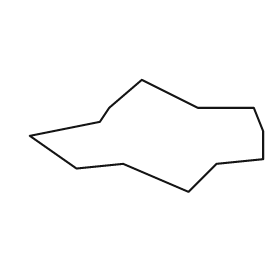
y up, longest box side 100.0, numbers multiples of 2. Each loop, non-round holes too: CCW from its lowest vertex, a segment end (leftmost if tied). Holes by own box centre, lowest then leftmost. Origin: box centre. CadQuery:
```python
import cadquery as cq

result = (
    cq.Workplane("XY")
    .moveTo(18.0, -24.0)
    .lineTo(30.0, -12.0)
    .lineTo(50.0, -10.0)
    .lineTo(50.0, 2.0)
    .lineTo(46.0, 12.0)
    .lineTo(22.0, 12.0)
    .lineTo(-2.0, 24.0)
    .lineTo(-16.0, 12.0)
    .lineTo(-20.0, 6.0)
    .lineTo(-50.0, 0.0)
    .lineTo(-30.0, -14.0)
    .lineTo(-10.0, -12.0)
    .close()
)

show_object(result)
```